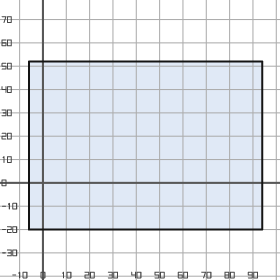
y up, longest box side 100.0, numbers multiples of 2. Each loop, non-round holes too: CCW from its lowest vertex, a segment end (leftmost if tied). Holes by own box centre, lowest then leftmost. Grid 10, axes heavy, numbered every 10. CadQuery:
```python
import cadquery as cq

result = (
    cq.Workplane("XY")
    .moveTo(-6.0, -20.0)
    .lineTo(94.0, -20.0)
    .lineTo(94.0, 52.0)
    .lineTo(-6.0, 52.0)
    .close()
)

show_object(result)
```